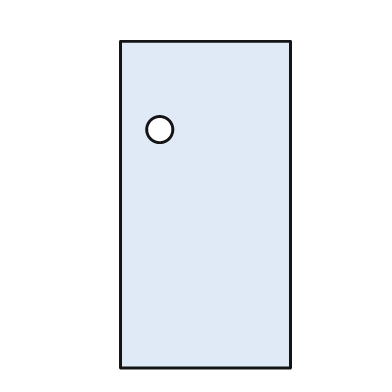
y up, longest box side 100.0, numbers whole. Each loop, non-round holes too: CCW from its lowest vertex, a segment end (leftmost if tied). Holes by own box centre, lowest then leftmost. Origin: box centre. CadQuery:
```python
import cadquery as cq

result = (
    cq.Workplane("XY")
    .moveTo(-26.0, -50.0)
    .lineTo(26.0, -50.0)
    .lineTo(26.0, 50.0)
    .lineTo(-26.0, 50.0)
    .close()
    .moveTo(-14.0, 23.0)
    .circle(4.0)
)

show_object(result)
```